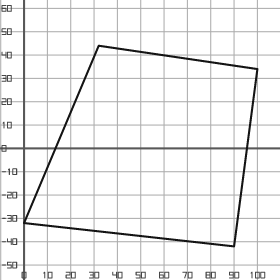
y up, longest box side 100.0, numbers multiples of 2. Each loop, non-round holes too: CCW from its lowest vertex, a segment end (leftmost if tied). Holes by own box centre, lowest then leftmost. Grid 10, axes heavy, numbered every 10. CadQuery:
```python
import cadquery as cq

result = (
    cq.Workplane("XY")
    .moveTo(90.0, -42.0)
    .lineTo(100.0, 34.0)
    .lineTo(32.0, 44.0)
    .lineTo(0.0, -32.0)
    .close()
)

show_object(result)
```